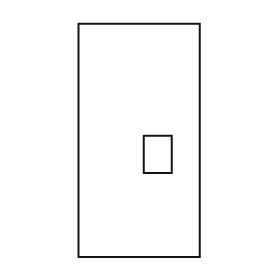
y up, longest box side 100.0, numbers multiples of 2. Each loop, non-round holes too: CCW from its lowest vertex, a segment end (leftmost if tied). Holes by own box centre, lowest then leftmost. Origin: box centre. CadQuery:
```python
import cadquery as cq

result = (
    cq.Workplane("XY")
    .moveTo(-26.0, -50.0)
    .lineTo(26.0, -50.0)
    .lineTo(26.0, 50.0)
    .lineTo(-26.0, 50.0)
    .close()
    .moveTo(2.0, -14.0)
    .lineTo(14.0, -14.0)
    .lineTo(14.0, 2.0)
    .lineTo(2.0, 2.0)
    .close()
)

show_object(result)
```